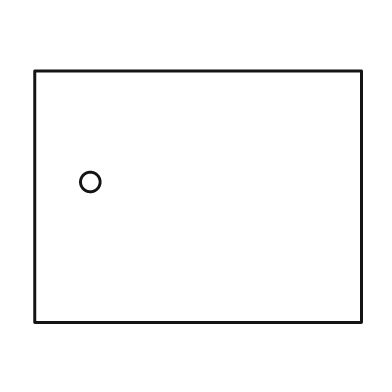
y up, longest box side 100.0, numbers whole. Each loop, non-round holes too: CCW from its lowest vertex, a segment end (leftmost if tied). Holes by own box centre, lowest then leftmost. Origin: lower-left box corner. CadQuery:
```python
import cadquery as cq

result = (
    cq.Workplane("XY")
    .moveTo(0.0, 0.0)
    .lineTo(100.0, 0.0)
    .lineTo(100.0, 77.0)
    .lineTo(0.0, 77.0)
    .close()
    .moveTo(17.0, 43.0)
    .circle(3.0)
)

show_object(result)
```